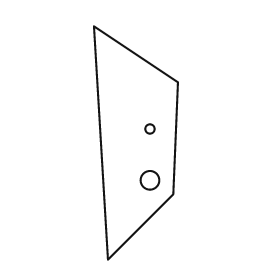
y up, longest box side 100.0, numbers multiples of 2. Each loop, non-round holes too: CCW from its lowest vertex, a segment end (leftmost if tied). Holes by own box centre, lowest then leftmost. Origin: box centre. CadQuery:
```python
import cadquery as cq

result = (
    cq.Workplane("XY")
    .moveTo(-12.0, -50.0)
    .lineTo(16.0, -22.0)
    .lineTo(18.0, 26.0)
    .lineTo(-18.0, 50.0)
    .close()
    .moveTo(6.0, -16.0)
    .circle(4.0)
    .moveTo(6.0, 6.0)
    .circle(2.0)
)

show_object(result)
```